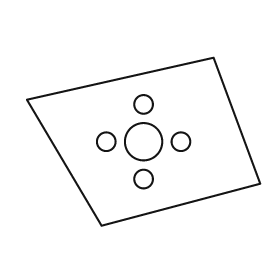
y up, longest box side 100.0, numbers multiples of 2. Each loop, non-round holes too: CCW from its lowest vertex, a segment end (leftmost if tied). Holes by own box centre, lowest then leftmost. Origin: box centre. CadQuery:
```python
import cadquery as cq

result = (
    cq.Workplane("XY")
    .moveTo(-18.0, -36.0)
    .lineTo(50.0, -18.0)
    .lineTo(30.0, 36.0)
    .lineTo(-50.0, 18.0)
    .close()
    .moveTo(0.0, -16.0)
    .circle(4.0)
    .moveTo(-16.0, 0.0)
    .circle(4.0)
    .moveTo(0.0, 0.0)
    .circle(8.0)
    .moveTo(16.0, 0.0)
    .circle(4.0)
    .moveTo(0.0, 16.0)
    .circle(4.0)
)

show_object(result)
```